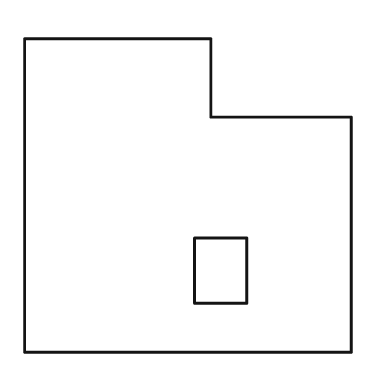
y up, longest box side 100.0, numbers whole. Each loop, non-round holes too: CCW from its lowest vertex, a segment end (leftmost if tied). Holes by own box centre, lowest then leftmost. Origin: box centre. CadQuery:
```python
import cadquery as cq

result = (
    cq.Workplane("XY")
    .moveTo(-50.0, -48.0)
    .lineTo(50.0, -48.0)
    .lineTo(50.0, 24.0)
    .lineTo(7.0, 24.0)
    .lineTo(7.0, 48.0)
    .lineTo(-50.0, 48.0)
    .close()
    .moveTo(2.0, -33.0)
    .lineTo(18.0, -33.0)
    .lineTo(18.0, -13.0)
    .lineTo(2.0, -13.0)
    .close()
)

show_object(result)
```